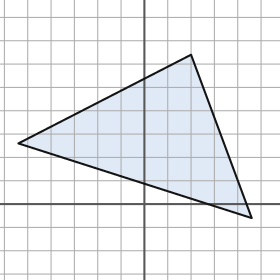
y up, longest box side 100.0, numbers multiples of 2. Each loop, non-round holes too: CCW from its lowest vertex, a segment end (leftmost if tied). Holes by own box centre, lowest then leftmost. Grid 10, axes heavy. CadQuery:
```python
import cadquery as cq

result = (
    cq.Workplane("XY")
    .moveTo(46.0, -6.0)
    .lineTo(20.0, 64.0)
    .lineTo(-54.0, 26.0)
    .close()
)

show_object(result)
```